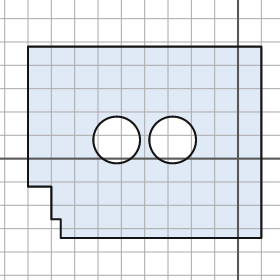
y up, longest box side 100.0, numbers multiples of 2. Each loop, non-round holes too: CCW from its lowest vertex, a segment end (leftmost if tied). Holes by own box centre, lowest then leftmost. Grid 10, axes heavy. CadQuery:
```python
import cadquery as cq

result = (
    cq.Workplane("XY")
    .moveTo(-76.0, -34.0)
    .lineTo(10.0, -34.0)
    .lineTo(10.0, 48.0)
    .lineTo(-90.0, 48.0)
    .lineTo(-90.0, -12.0)
    .lineTo(-80.0, -12.0)
    .lineTo(-80.0, -26.0)
    .lineTo(-76.0, -26.0)
    .close()
    .moveTo(-52.0, 8.0)
    .circle(10.0)
    .moveTo(-28.0, 8.0)
    .circle(10.0)
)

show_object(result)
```